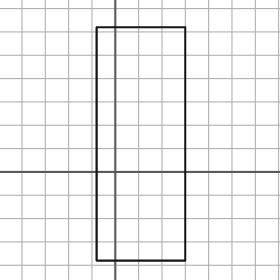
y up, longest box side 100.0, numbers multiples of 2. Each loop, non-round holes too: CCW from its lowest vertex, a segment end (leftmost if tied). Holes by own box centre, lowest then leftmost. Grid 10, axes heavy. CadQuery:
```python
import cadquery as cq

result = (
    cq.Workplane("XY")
    .moveTo(-8.0, -38.0)
    .lineTo(30.0, -38.0)
    .lineTo(30.0, 62.0)
    .lineTo(-8.0, 62.0)
    .close()
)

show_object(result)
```